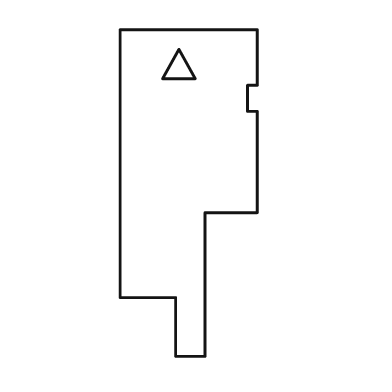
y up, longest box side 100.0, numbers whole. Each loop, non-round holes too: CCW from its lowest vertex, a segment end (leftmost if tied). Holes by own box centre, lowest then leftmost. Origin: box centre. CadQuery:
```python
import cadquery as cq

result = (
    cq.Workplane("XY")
    .moveTo(-4.0, -50.0)
    .lineTo(5.0, -50.0)
    .lineTo(5.0, -6.0)
    .lineTo(21.0, -6.0)
    .lineTo(21.0, 25.0)
    .lineTo(18.0, 25.0)
    .lineTo(18.0, 33.0)
    .lineTo(21.0, 33.0)
    .lineTo(21.0, 50.0)
    .lineTo(-21.0, 50.0)
    .lineTo(-21.0, -32.0)
    .lineTo(-4.0, -32.0)
    .close()
    .moveTo(-8.0, 35.0)
    .lineTo(2.0, 35.0)
    .lineTo(-3.0, 44.0)
    .close()
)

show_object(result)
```